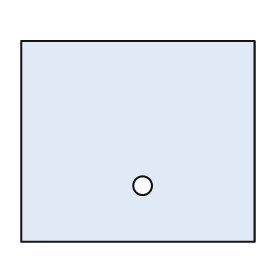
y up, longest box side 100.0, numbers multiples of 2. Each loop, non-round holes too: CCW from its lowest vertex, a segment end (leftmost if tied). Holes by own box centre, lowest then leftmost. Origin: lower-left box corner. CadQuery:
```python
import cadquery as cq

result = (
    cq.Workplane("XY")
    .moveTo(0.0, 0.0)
    .lineTo(100.0, 0.0)
    .lineTo(100.0, 86.0)
    .lineTo(0.0, 86.0)
    .close()
    .moveTo(52.0, 24.0)
    .circle(4.0)
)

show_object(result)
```